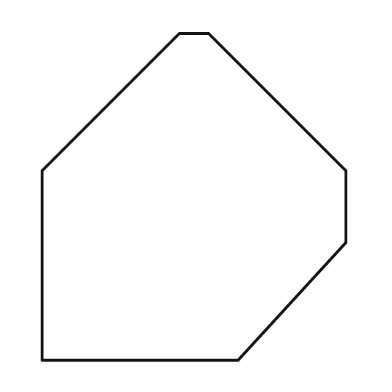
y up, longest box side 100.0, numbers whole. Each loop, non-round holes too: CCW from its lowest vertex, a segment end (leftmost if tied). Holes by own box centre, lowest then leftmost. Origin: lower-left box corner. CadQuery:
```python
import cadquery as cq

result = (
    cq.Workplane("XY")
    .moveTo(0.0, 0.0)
    .lineTo(60.0, 0.0)
    .lineTo(93.0, 36.0)
    .lineTo(93.0, 58.0)
    .lineTo(51.0, 100.0)
    .lineTo(42.0, 100.0)
    .lineTo(0.0, 58.0)
    .close()
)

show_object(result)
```